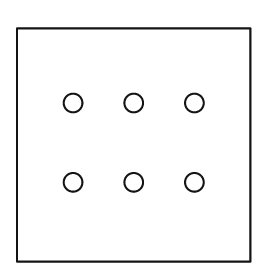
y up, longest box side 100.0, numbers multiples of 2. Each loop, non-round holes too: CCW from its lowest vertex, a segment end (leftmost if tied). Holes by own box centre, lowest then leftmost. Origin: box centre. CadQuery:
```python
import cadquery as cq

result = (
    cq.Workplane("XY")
    .moveTo(-50.0, -50.0)
    .lineTo(50.0, -50.0)
    .lineTo(50.0, 50.0)
    .lineTo(-50.0, 50.0)
    .close()
    .moveTo(-26.0, -16.0)
    .circle(4.0)
    .moveTo(0.0, -16.0)
    .circle(4.0)
    .moveTo(26.0, -16.0)
    .circle(4.0)
    .moveTo(-26.0, 18.0)
    .circle(4.0)
    .moveTo(0.0, 18.0)
    .circle(4.0)
    .moveTo(26.0, 18.0)
    .circle(4.0)
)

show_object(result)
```